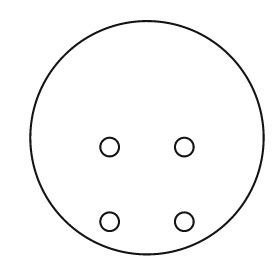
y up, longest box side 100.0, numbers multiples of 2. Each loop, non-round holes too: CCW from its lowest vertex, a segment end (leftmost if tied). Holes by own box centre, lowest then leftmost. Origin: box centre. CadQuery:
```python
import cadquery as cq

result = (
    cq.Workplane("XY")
    .moveTo(0.0, 0.0)
    .circle(50.0)
    .moveTo(-16.0, -36.0)
    .circle(4.0)
    .moveTo(16.0, -36.0)
    .circle(4.0)
    .moveTo(-16.0, -4.0)
    .circle(4.0)
    .moveTo(16.0, -4.0)
    .circle(4.0)
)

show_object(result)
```